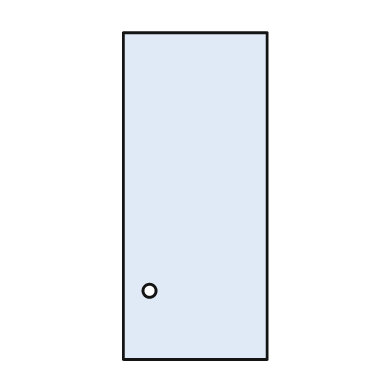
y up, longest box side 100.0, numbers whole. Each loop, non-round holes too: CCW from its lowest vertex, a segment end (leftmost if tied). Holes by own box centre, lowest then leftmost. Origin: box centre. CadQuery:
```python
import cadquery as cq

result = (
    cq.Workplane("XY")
    .moveTo(-22.0, -50.0)
    .lineTo(22.0, -50.0)
    .lineTo(22.0, 50.0)
    .lineTo(-22.0, 50.0)
    .close()
    .moveTo(-14.0, -29.0)
    .circle(2.0)
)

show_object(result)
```